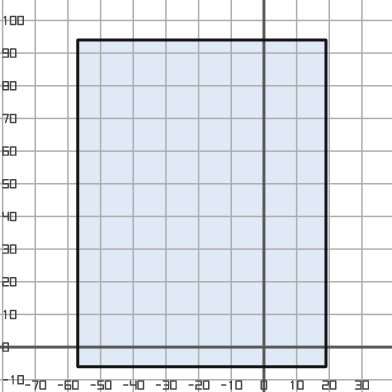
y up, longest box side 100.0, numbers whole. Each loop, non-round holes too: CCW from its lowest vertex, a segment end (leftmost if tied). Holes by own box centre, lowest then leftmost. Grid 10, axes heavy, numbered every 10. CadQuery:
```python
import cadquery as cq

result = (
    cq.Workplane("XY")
    .moveTo(-57.0, -6.0)
    .lineTo(19.0, -6.0)
    .lineTo(19.0, 94.0)
    .lineTo(-57.0, 94.0)
    .close()
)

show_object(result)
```